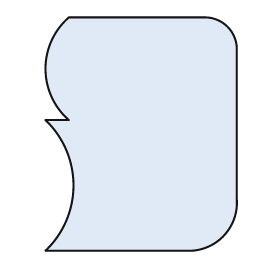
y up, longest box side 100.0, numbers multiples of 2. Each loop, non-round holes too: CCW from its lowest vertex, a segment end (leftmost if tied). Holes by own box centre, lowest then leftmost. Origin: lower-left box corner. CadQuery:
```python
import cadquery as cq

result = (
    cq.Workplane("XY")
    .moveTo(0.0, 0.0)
    .lineTo(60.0, 0.0)
    .threePointArc((76.0, 6.0), (82.0, 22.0))
    .lineTo(82.0, 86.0)
    .threePointArc((78.0, 96.0), (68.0, 100.0))
    .lineTo(10.0, 100.0)
    .threePointArc((0.0, 78.0), (10.0, 56.0))
    .lineTo(0.0, 56.0)
    .threePointArc((12.0, 28.0), (0.0, 0.0))
    .close()
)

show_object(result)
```